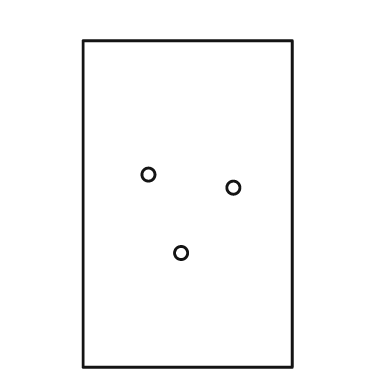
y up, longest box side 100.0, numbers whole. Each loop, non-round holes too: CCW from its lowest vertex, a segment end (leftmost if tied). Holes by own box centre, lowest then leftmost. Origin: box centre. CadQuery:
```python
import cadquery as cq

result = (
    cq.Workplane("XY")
    .moveTo(-32.0, -50.0)
    .lineTo(32.0, -50.0)
    .lineTo(32.0, 50.0)
    .lineTo(-32.0, 50.0)
    .close()
    .moveTo(-2.0, -15.0)
    .circle(2.0)
    .moveTo(14.0, 5.0)
    .circle(2.0)
    .moveTo(-12.0, 9.0)
    .circle(2.0)
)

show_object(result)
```